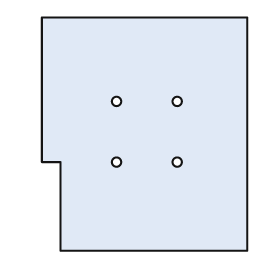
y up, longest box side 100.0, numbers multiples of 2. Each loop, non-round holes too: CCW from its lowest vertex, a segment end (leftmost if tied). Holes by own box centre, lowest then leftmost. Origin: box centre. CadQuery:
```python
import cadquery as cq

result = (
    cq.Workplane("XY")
    .moveTo(-36.0, -50.0)
    .lineTo(44.0, -50.0)
    .lineTo(44.0, 50.0)
    .lineTo(-44.0, 50.0)
    .lineTo(-44.0, -12.0)
    .lineTo(-36.0, -12.0)
    .close()
    .moveTo(-12.0, -12.0)
    .circle(2.0)
    .moveTo(14.0, -12.0)
    .circle(2.0)
    .moveTo(-12.0, 14.0)
    .circle(2.0)
    .moveTo(14.0, 14.0)
    .circle(2.0)
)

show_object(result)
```